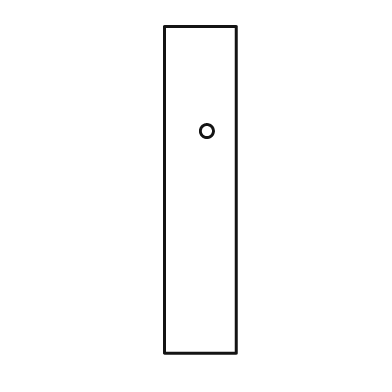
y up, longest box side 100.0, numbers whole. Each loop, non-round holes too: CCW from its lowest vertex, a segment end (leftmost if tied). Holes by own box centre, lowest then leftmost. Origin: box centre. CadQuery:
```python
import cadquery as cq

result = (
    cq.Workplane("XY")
    .moveTo(-11.0, -50.0)
    .lineTo(11.0, -50.0)
    .lineTo(11.0, 50.0)
    .lineTo(-11.0, 50.0)
    .close()
    .moveTo(2.0, 18.0)
    .circle(2.0)
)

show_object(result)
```